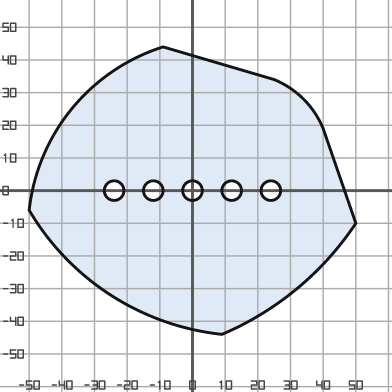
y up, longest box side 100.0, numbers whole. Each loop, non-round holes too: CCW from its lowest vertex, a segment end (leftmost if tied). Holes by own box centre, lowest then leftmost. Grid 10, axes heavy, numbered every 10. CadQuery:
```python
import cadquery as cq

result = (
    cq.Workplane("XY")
    .moveTo(9.0, -44.0)
    .threePointArc((32.0, -30.0), (50.0, -10.0))
    .lineTo(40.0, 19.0)
    .threePointArc((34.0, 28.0), (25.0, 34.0))
    .lineTo(-9.0, 44.0)
    .threePointArc((-37.0, 25.0), (-50.0, -6.0))
    .threePointArc((-25.0, -32.0), (9.0, -44.0))
    .close()
    .moveTo(-24.0, 0.0)
    .circle(3.0)
    .moveTo(-12.0, 0.0)
    .circle(3.0)
    .moveTo(0.0, 0.0)
    .circle(3.0)
    .moveTo(12.0, 0.0)
    .circle(3.0)
    .moveTo(24.0, 0.0)
    .circle(3.0)
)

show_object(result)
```